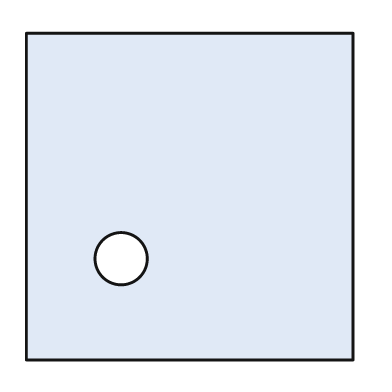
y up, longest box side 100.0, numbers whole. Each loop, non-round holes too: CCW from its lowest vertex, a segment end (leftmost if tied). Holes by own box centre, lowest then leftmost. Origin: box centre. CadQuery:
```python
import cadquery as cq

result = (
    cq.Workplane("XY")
    .moveTo(-50.0, -50.0)
    .lineTo(50.0, -50.0)
    .lineTo(50.0, 50.0)
    .lineTo(-50.0, 50.0)
    .close()
    .moveTo(-21.0, -19.0)
    .circle(8.0)
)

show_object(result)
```